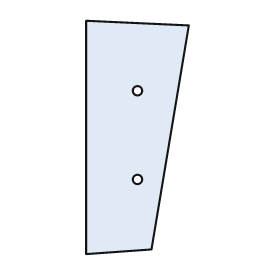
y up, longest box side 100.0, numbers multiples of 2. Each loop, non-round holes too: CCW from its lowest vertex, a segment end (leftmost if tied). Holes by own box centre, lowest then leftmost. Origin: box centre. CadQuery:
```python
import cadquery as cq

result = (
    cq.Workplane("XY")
    .moveTo(-22.0, -50.0)
    .lineTo(6.0, -48.0)
    .lineTo(22.0, 48.0)
    .lineTo(-22.0, 50.0)
    .close()
    .moveTo(0.0, -18.0)
    .circle(2.0)
    .moveTo(0.0, 20.0)
    .circle(2.0)
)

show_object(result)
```